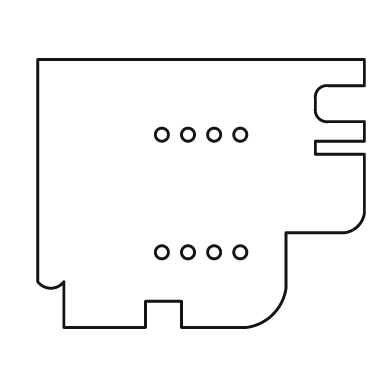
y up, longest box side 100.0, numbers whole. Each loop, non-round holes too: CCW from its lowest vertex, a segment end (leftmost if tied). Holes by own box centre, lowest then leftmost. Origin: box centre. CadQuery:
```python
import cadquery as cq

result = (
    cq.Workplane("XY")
    .moveTo(-42.0, -41.0)
    .lineTo(-17.0, -41.0)
    .lineTo(-17.0, -33.0)
    .lineTo(-6.0, -33.0)
    .lineTo(-6.0, -41.0)
    .lineTo(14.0, -41.0)
    .threePointArc((22.0, -37.0), (26.0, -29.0))
    .lineTo(26.0, -12.0)
    .lineTo(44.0, -12.0)
    .threePointArc((48.0, -10.0), (50.0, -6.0))
    .lineTo(50.0, 12.0)
    .lineTo(35.0, 12.0)
    .lineTo(35.0, 16.0)
    .lineTo(50.0, 16.0)
    .lineTo(50.0, 22.0)
    .lineTo(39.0, 22.0)
    .threePointArc((36.0, 23.0), (35.0, 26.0))
    .lineTo(35.0, 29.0)
    .threePointArc((36.0, 32.0), (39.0, 33.0))
    .lineTo(50.0, 33.0)
    .lineTo(50.0, 41.0)
    .lineTo(-50.0, 41.0)
    .lineTo(-50.0, -27.0)
    .threePointArc((-46.0, -29.0), (-42.0, -27.0))
    .close()
    .moveTo(-12.0, -18.0)
    .circle(2.0)
    .moveTo(-4.0, -18.0)
    .circle(2.0)
    .moveTo(4.0, -18.0)
    .circle(2.0)
    .moveTo(12.0, -18.0)
    .circle(2.0)
    .moveTo(-12.0, 18.0)
    .circle(2.0)
    .moveTo(-4.0, 18.0)
    .circle(2.0)
    .moveTo(4.0, 18.0)
    .circle(2.0)
    .moveTo(12.0, 18.0)
    .circle(2.0)
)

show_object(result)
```